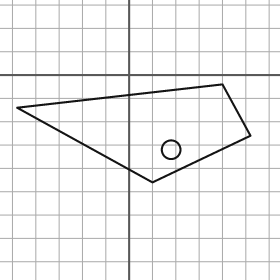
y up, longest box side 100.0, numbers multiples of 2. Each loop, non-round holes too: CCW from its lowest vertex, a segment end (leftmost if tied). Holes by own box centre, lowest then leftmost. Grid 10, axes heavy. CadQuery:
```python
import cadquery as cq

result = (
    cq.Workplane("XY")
    .moveTo(10.0, -46.0)
    .lineTo(52.0, -26.0)
    .lineTo(40.0, -4.0)
    .lineTo(-48.0, -14.0)
    .close()
    .moveTo(18.0, -32.0)
    .circle(4.0)
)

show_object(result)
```